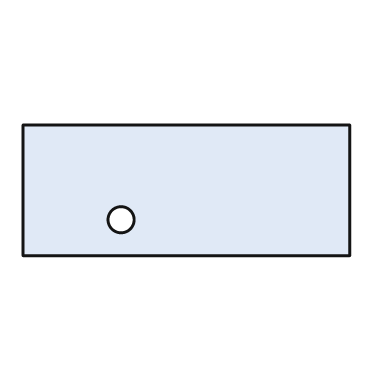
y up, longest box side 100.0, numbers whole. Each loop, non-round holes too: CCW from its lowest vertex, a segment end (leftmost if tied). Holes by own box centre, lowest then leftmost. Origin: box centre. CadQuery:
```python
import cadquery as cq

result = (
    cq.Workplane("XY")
    .moveTo(-50.0, -20.0)
    .lineTo(50.0, -20.0)
    .lineTo(50.0, 20.0)
    .lineTo(-50.0, 20.0)
    .close()
    .moveTo(-20.0, -9.0)
    .circle(4.0)
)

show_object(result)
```